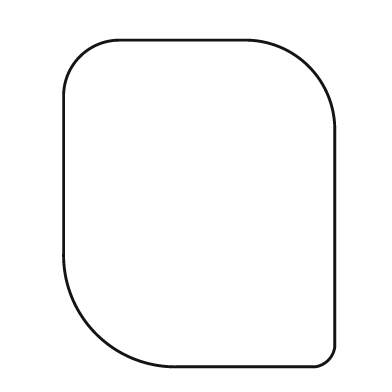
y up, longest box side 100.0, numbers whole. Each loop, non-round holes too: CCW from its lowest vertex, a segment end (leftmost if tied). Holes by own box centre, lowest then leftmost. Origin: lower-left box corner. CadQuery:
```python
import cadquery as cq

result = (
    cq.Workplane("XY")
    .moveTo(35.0, 0.0)
    .lineTo(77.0, 0.0)
    .threePointArc((81.0, 2.0), (83.0, 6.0))
    .lineTo(83.0, 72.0)
    .threePointArc((75.0, 92.0), (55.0, 100.0))
    .lineTo(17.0, 100.0)
    .threePointArc((5.0, 95.0), (0.0, 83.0))
    .lineTo(0.0, 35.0)
    .threePointArc((10.0, 10.0), (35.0, 0.0))
    .close()
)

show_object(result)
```